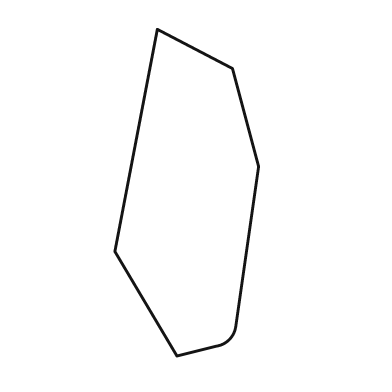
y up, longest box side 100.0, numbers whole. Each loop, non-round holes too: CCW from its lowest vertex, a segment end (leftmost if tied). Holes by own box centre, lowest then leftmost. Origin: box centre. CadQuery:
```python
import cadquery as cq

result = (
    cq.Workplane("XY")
    .moveTo(-3.0, -50.0)
    .lineTo(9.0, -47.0)
    .threePointArc((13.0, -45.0), (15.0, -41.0))
    .lineTo(22.0, 8.0)
    .lineTo(14.0, 38.0)
    .lineTo(-9.0, 50.0)
    .lineTo(-22.0, -18.0)
    .close()
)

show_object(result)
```